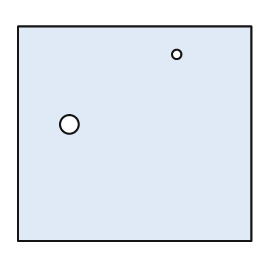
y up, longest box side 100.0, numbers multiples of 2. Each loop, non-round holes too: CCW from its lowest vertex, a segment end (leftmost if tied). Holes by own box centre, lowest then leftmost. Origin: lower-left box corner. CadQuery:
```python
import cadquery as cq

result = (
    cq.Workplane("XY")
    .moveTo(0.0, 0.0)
    .lineTo(100.0, 0.0)
    .lineTo(100.0, 92.0)
    .lineTo(0.0, 92.0)
    .close()
    .moveTo(22.0, 50.0)
    .circle(4.0)
    .moveTo(68.0, 80.0)
    .circle(2.0)
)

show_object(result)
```